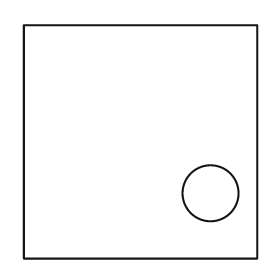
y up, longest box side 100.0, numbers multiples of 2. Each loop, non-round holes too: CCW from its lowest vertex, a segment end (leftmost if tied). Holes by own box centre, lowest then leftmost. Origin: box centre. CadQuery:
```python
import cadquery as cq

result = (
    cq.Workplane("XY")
    .moveTo(-50.0, -50.0)
    .lineTo(50.0, -50.0)
    .lineTo(50.0, 50.0)
    .lineTo(-50.0, 50.0)
    .close()
    .moveTo(30.0, -22.0)
    .circle(12.0)
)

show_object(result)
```